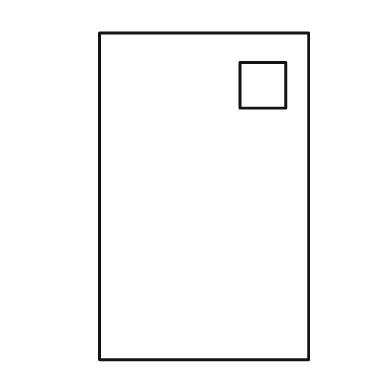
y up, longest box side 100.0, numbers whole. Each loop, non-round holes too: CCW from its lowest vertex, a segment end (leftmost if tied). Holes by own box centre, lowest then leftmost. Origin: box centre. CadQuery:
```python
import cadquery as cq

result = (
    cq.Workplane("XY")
    .moveTo(-32.0, -50.0)
    .lineTo(32.0, -50.0)
    .lineTo(32.0, 50.0)
    .lineTo(-32.0, 50.0)
    .close()
    .moveTo(11.0, 27.0)
    .lineTo(25.0, 27.0)
    .lineTo(25.0, 41.0)
    .lineTo(11.0, 41.0)
    .close()
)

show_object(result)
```